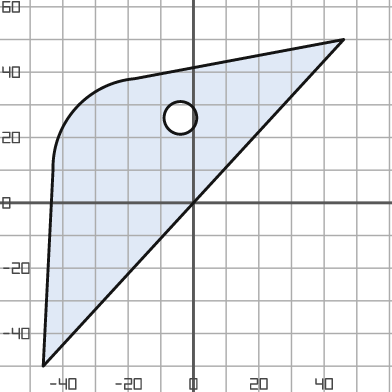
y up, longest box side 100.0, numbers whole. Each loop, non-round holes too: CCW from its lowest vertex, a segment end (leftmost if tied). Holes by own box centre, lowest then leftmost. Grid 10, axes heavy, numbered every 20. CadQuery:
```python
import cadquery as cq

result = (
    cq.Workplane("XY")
    .moveTo(-46.0, -50.0)
    .lineTo(46.0, 50.0)
    .lineTo(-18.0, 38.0)
    .threePointArc((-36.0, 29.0), (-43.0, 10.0))
    .close()
    .moveTo(-4.0, 26.0)
    .circle(5.0)
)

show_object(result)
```